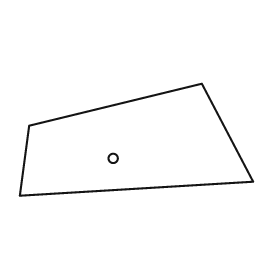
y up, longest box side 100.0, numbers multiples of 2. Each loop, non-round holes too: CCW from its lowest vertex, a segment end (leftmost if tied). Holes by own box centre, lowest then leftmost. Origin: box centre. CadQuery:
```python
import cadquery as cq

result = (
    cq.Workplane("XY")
    .moveTo(-50.0, -24.0)
    .lineTo(50.0, -18.0)
    .lineTo(28.0, 24.0)
    .lineTo(-46.0, 6.0)
    .close()
    .moveTo(-10.0, -8.0)
    .circle(2.0)
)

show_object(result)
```